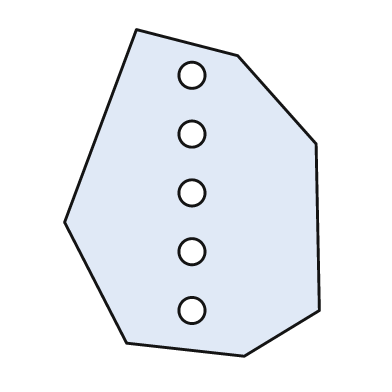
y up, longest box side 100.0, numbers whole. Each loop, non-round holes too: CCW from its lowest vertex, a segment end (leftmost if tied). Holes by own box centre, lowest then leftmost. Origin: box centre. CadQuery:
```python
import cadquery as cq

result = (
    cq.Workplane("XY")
    .moveTo(16.0, -50.0)
    .lineTo(39.0, -36.0)
    .lineTo(38.0, 15.0)
    .lineTo(14.0, 42.0)
    .lineTo(-17.0, 50.0)
    .lineTo(-39.0, -9.0)
    .lineTo(-20.0, -46.0)
    .close()
    .moveTo(0.0, -36.0)
    .circle(4.0)
    .moveTo(0.0, -18.0)
    .circle(4.0)
    .moveTo(0.0, 0.0)
    .circle(4.0)
    .moveTo(0.0, 18.0)
    .circle(4.0)
    .moveTo(0.0, 36.0)
    .circle(4.0)
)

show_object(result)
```